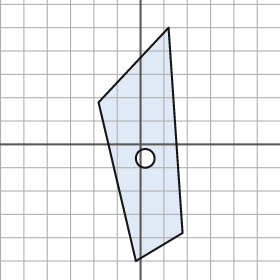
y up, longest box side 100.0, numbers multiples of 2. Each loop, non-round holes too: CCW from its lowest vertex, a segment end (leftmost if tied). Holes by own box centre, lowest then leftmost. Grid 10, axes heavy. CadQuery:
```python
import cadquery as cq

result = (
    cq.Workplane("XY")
    .moveTo(-2.0, -50.0)
    .lineTo(18.0, -38.0)
    .lineTo(12.0, 50.0)
    .lineTo(-18.0, 18.0)
    .close()
    .moveTo(2.0, -6.0)
    .circle(4.0)
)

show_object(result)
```